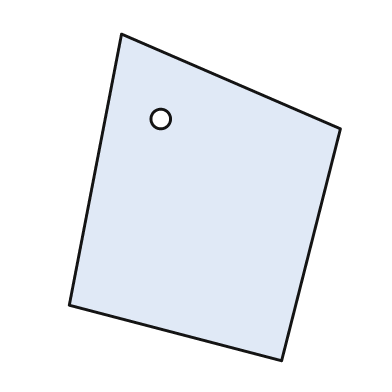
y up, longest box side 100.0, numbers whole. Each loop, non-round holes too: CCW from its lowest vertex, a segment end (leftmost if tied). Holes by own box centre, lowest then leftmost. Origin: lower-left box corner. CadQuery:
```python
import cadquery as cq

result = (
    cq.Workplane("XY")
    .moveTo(65.0, 0.0)
    .lineTo(83.0, 71.0)
    .lineTo(16.0, 100.0)
    .lineTo(0.0, 17.0)
    .close()
    .moveTo(28.0, 74.0)
    .circle(3.0)
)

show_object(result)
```